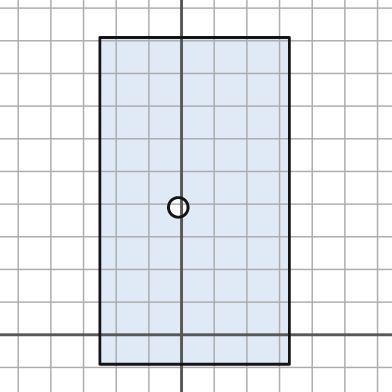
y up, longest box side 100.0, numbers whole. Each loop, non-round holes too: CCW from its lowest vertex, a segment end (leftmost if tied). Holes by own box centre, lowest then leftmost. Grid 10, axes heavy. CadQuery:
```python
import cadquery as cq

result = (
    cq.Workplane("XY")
    .moveTo(-25.0, -9.0)
    .lineTo(33.0, -9.0)
    .lineTo(33.0, 91.0)
    .lineTo(-25.0, 91.0)
    .close()
    .moveTo(-1.0, 39.0)
    .circle(3.0)
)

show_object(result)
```